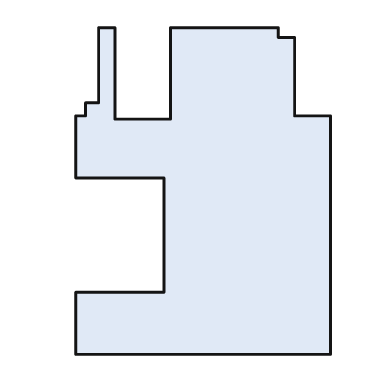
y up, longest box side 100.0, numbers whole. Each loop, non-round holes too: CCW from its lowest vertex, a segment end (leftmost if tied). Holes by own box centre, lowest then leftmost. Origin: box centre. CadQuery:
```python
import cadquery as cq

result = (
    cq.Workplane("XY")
    .moveTo(-39.0, -50.0)
    .lineTo(39.0, -50.0)
    .lineTo(39.0, 23.0)
    .lineTo(28.0, 23.0)
    .lineTo(28.0, 47.0)
    .lineTo(23.0, 47.0)
    .lineTo(23.0, 50.0)
    .lineTo(-10.0, 50.0)
    .lineTo(-10.0, 22.0)
    .lineTo(-27.0, 22.0)
    .lineTo(-27.0, 50.0)
    .lineTo(-32.0, 50.0)
    .lineTo(-32.0, 27.0)
    .lineTo(-36.0, 27.0)
    .lineTo(-36.0, 23.0)
    .lineTo(-39.0, 23.0)
    .lineTo(-39.0, 4.0)
    .lineTo(-12.0, 4.0)
    .lineTo(-12.0, -31.0)
    .lineTo(-39.0, -31.0)
    .close()
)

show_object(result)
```